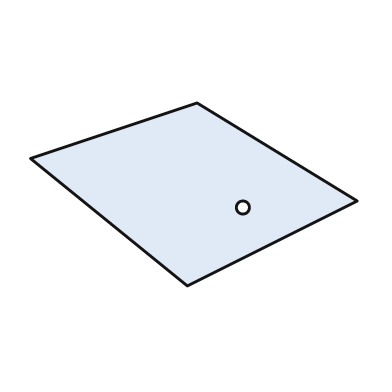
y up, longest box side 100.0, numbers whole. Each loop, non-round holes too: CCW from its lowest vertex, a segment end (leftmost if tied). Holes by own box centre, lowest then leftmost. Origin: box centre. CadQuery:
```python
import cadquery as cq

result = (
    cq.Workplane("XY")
    .moveTo(-2.0, -28.0)
    .lineTo(50.0, -2.0)
    .lineTo(1.0, 28.0)
    .lineTo(-50.0, 11.0)
    .close()
    .moveTo(15.0, -4.0)
    .circle(2.0)
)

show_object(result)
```